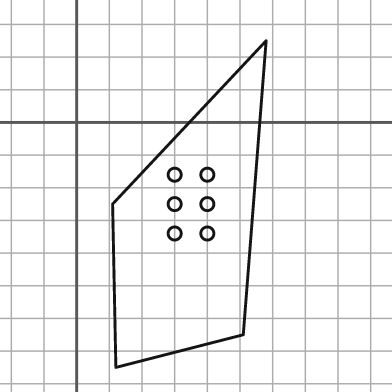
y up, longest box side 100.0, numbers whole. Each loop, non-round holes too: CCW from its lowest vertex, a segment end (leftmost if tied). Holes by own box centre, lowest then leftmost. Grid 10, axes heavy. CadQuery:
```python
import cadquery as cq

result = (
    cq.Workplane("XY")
    .moveTo(12.0, -75.0)
    .lineTo(51.0, -65.0)
    .lineTo(58.0, 25.0)
    .lineTo(11.0, -25.0)
    .close()
    .moveTo(30.0, -34.0)
    .circle(2.0)
    .moveTo(40.0, -34.0)
    .circle(2.0)
    .moveTo(30.0, -25.0)
    .circle(2.0)
    .moveTo(40.0, -25.0)
    .circle(2.0)
    .moveTo(30.0, -16.0)
    .circle(2.0)
    .moveTo(40.0, -16.0)
    .circle(2.0)
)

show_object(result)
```